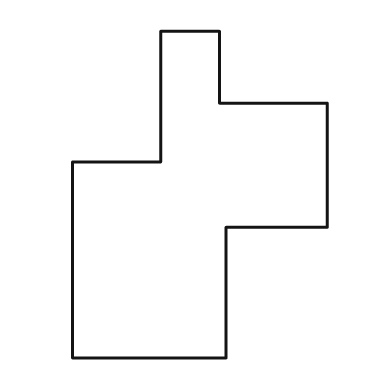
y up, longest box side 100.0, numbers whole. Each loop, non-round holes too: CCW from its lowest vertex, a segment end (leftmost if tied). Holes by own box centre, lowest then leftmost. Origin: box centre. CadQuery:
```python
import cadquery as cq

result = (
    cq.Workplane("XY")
    .moveTo(-39.0, -50.0)
    .lineTo(8.0, -50.0)
    .lineTo(8.0, -10.0)
    .lineTo(39.0, -10.0)
    .lineTo(39.0, 28.0)
    .lineTo(6.0, 28.0)
    .lineTo(6.0, 50.0)
    .lineTo(-12.0, 50.0)
    .lineTo(-12.0, 10.0)
    .lineTo(-39.0, 10.0)
    .close()
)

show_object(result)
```